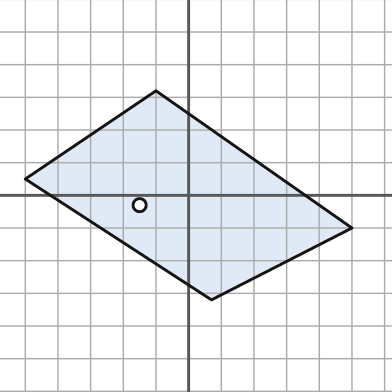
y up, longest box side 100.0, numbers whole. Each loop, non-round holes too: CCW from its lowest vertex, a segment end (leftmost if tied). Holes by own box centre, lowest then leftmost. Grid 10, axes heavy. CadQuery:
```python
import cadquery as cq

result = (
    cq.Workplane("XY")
    .moveTo(7.0, -32.0)
    .lineTo(50.0, -10.0)
    .lineTo(-10.0, 32.0)
    .lineTo(-50.0, 5.0)
    .close()
    .moveTo(-15.0, -3.0)
    .circle(2.0)
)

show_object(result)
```